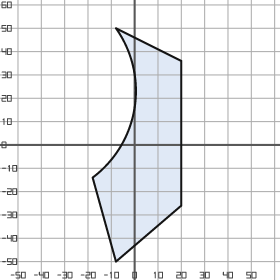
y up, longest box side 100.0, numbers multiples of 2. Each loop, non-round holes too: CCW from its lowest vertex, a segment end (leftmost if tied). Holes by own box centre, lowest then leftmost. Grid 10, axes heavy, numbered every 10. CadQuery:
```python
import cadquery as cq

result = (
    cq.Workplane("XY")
    .moveTo(-8.0, -50.0)
    .lineTo(20.0, -26.0)
    .lineTo(20.0, 36.0)
    .lineTo(-8.0, 50.0)
    .threePointArc((0.0, 16.0), (-18.0, -14.0))
    .close()
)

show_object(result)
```